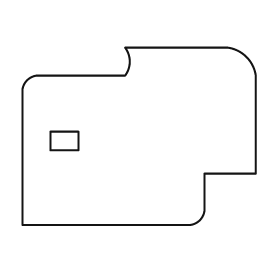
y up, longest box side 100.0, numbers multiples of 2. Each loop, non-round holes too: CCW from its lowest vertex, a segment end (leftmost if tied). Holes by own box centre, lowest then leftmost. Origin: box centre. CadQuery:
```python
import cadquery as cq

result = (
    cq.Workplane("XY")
    .moveTo(-50.0, -38.0)
    .lineTo(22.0, -38.0)
    .threePointArc((26.0, -36.0), (28.0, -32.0))
    .lineTo(28.0, -16.0)
    .lineTo(50.0, -16.0)
    .lineTo(50.0, 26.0)
    .threePointArc((46.0, 34.0), (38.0, 38.0))
    .lineTo(-6.0, 38.0)
    .threePointArc((-4.0, 32.0), (-6.0, 26.0))
    .lineTo(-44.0, 26.0)
    .threePointArc((-48.0, 24.0), (-50.0, 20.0))
    .close()
    .moveTo(-38.0, -6.0)
    .lineTo(-26.0, -6.0)
    .lineTo(-26.0, 2.0)
    .lineTo(-38.0, 2.0)
    .close()
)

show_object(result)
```